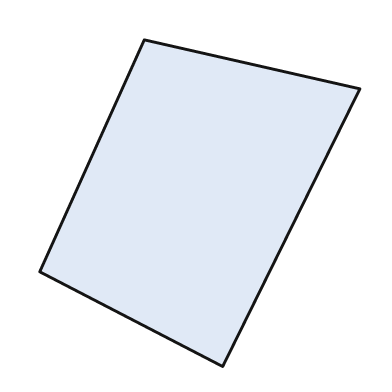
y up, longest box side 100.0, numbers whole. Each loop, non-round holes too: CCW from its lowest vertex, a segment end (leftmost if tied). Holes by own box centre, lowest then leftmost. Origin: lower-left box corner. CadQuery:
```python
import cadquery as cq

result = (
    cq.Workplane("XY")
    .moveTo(56.0, 0.0)
    .lineTo(98.0, 85.0)
    .lineTo(32.0, 100.0)
    .lineTo(0.0, 29.0)
    .close()
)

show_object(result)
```